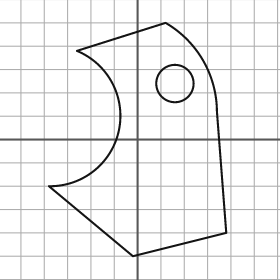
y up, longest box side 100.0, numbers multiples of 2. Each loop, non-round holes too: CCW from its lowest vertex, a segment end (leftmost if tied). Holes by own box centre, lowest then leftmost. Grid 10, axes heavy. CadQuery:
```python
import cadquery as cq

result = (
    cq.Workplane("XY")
    .moveTo(-2.0, -50.0)
    .lineTo(38.0, -40.0)
    .lineTo(34.0, 12.0)
    .threePointArc((28.0, 34.0), (12.0, 50.0))
    .lineTo(-26.0, 38.0)
    .threePointArc((-8.0, 4.0), (-38.0, -20.0))
    .close()
    .moveTo(16.0, 24.0)
    .circle(8.0)
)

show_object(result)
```